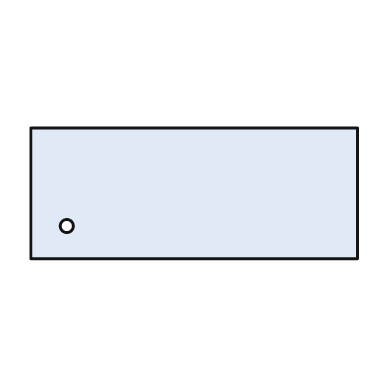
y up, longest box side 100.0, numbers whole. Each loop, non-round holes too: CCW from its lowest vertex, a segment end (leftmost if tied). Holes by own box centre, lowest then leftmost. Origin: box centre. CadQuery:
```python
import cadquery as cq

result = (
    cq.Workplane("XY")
    .moveTo(-50.0, -20.0)
    .lineTo(50.0, -20.0)
    .lineTo(50.0, 20.0)
    .lineTo(-50.0, 20.0)
    .close()
    .moveTo(-39.0, -10.0)
    .circle(2.0)
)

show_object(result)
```